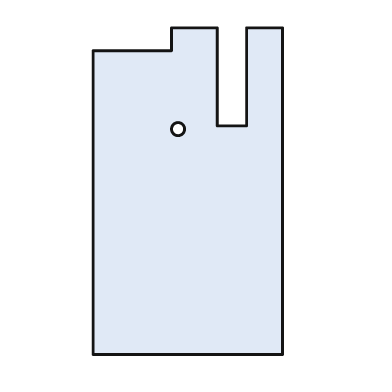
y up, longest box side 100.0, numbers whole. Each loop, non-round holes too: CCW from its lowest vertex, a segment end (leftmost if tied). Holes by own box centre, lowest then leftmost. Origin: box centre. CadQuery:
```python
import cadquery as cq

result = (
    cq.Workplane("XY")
    .moveTo(-29.0, -50.0)
    .lineTo(29.0, -50.0)
    .lineTo(29.0, 50.0)
    .lineTo(18.0, 50.0)
    .lineTo(18.0, 20.0)
    .lineTo(9.0, 20.0)
    .lineTo(9.0, 50.0)
    .lineTo(-5.0, 50.0)
    .lineTo(-5.0, 43.0)
    .lineTo(-29.0, 43.0)
    .close()
    .moveTo(-3.0, 19.0)
    .circle(2.0)
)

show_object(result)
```